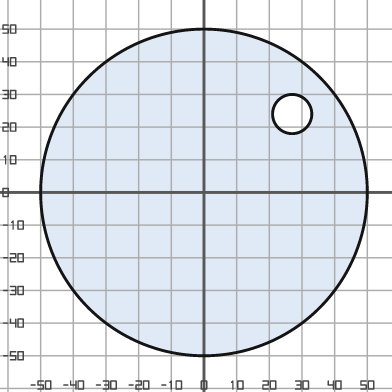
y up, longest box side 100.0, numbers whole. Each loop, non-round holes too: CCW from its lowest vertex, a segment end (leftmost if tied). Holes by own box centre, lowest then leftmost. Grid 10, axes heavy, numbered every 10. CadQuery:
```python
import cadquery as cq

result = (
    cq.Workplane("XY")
    .moveTo(0.0, 0.0)
    .circle(50.0)
    .moveTo(27.0, 24.0)
    .circle(6.0)
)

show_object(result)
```